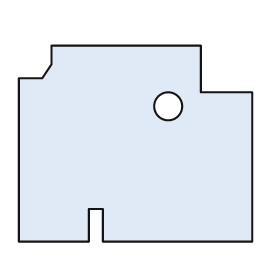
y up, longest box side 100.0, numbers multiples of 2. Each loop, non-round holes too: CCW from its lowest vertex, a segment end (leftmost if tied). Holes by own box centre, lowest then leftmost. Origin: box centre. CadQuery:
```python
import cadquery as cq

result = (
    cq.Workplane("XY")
    .moveTo(-50.0, -42.0)
    .lineTo(-20.0, -42.0)
    .lineTo(-20.0, -28.0)
    .lineTo(-14.0, -28.0)
    .lineTo(-14.0, -42.0)
    .lineTo(50.0, -42.0)
    .lineTo(50.0, 22.0)
    .lineTo(28.0, 22.0)
    .lineTo(28.0, 42.0)
    .lineTo(-36.0, 42.0)
    .lineTo(-36.0, 34.0)
    .lineTo(-40.0, 28.0)
    .lineTo(-50.0, 28.0)
    .close()
    .moveTo(14.0, 16.0)
    .circle(6.0)
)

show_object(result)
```